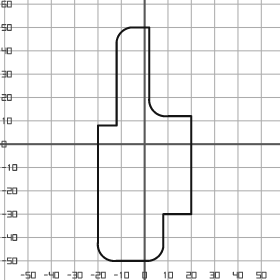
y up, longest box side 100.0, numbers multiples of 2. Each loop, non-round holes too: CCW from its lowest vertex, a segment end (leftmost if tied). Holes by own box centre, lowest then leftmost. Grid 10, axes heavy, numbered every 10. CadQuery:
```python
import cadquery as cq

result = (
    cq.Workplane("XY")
    .moveTo(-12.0, -50.0)
    .lineTo(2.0, -50.0)
    .threePointArc((6.0, -48.0), (8.0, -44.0))
    .lineTo(8.0, -30.0)
    .lineTo(20.0, -30.0)
    .lineTo(20.0, 12.0)
    .lineTo(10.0, 12.0)
    .threePointArc((4.0, 14.0), (2.0, 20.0))
    .lineTo(2.0, 50.0)
    .lineTo(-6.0, 50.0)
    .threePointArc((-10.0, 48.0), (-12.0, 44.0))
    .lineTo(-12.0, 8.0)
    .lineTo(-20.0, 8.0)
    .lineTo(-20.0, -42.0)
    .threePointArc((-18.0, -48.0), (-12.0, -50.0))
    .close()
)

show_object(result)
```